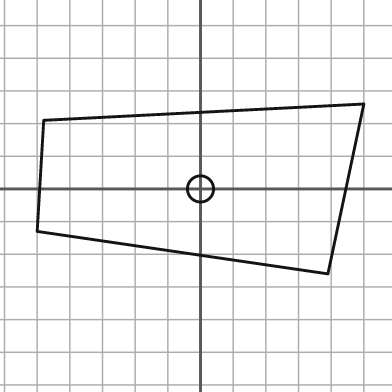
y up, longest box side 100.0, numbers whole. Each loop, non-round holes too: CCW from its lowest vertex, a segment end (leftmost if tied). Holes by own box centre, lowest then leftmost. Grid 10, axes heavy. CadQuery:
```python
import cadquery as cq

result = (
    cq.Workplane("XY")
    .moveTo(39.0, -26.0)
    .lineTo(50.0, 26.0)
    .lineTo(-48.0, 21.0)
    .lineTo(-50.0, -13.0)
    .close()
    .moveTo(0.0, 0.0)
    .circle(4.0)
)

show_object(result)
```